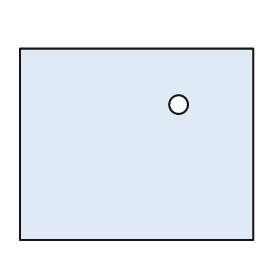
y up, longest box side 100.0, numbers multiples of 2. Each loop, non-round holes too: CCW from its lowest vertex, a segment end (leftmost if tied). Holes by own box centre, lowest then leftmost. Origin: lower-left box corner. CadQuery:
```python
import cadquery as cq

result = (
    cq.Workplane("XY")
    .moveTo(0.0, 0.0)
    .lineTo(100.0, 0.0)
    .lineTo(100.0, 82.0)
    .lineTo(0.0, 82.0)
    .close()
    .moveTo(68.0, 58.0)
    .circle(4.0)
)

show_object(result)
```